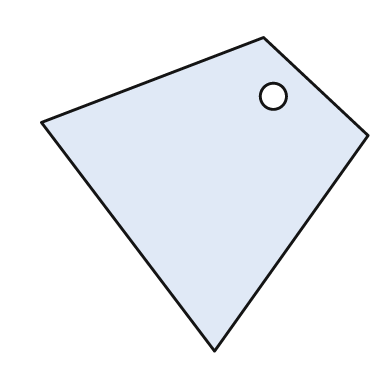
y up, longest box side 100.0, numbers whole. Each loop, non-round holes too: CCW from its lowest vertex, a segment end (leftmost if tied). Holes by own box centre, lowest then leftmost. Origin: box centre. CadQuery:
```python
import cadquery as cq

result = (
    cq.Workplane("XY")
    .moveTo(3.0, -48.0)
    .lineTo(50.0, 18.0)
    .lineTo(18.0, 48.0)
    .lineTo(-50.0, 22.0)
    .close()
    .moveTo(21.0, 30.0)
    .circle(4.0)
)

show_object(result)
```